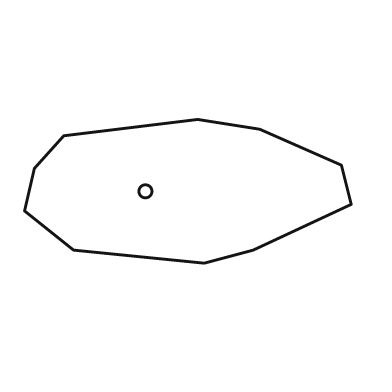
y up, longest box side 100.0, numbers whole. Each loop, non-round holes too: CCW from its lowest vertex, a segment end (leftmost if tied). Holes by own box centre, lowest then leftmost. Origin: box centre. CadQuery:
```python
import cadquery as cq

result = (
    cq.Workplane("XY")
    .moveTo(5.0, -22.0)
    .lineTo(20.0, -18.0)
    .lineTo(50.0, -4.0)
    .lineTo(47.0, 8.0)
    .lineTo(22.0, 19.0)
    .lineTo(3.0, 22.0)
    .lineTo(-38.0, 17.0)
    .lineTo(-47.0, 7.0)
    .lineTo(-50.0, -6.0)
    .lineTo(-35.0, -18.0)
    .close()
    .moveTo(-13.0, 0.0)
    .circle(2.0)
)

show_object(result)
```